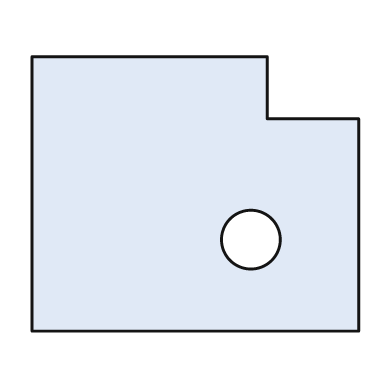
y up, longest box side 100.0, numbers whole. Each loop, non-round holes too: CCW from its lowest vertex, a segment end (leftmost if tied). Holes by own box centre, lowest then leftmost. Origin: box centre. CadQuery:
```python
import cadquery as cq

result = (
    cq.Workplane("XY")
    .moveTo(-50.0, -42.0)
    .lineTo(50.0, -42.0)
    .lineTo(50.0, 23.0)
    .lineTo(22.0, 23.0)
    .lineTo(22.0, 42.0)
    .lineTo(-50.0, 42.0)
    .close()
    .moveTo(17.0, -14.0)
    .circle(9.0)
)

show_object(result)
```